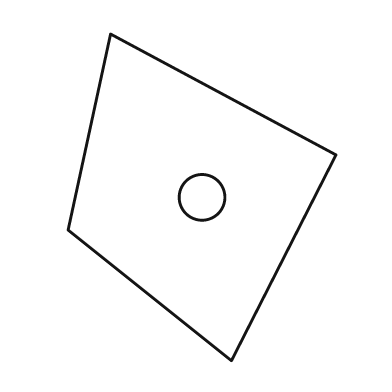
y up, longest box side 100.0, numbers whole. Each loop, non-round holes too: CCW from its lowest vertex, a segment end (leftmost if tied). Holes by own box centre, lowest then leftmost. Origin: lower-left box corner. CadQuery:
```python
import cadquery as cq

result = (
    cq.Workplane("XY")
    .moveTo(50.0, 0.0)
    .lineTo(82.0, 63.0)
    .lineTo(13.0, 100.0)
    .lineTo(0.0, 40.0)
    .close()
    .moveTo(41.0, 50.0)
    .circle(7.0)
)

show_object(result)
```